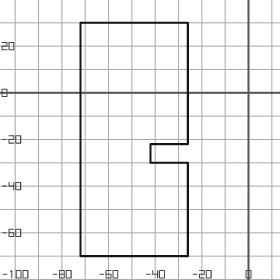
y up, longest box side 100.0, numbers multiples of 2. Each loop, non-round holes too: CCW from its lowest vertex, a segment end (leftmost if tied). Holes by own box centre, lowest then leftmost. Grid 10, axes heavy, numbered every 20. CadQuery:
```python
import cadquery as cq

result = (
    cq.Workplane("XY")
    .moveTo(-72.0, -70.0)
    .lineTo(-26.0, -70.0)
    .lineTo(-26.0, -30.0)
    .lineTo(-42.0, -30.0)
    .lineTo(-42.0, -22.0)
    .lineTo(-26.0, -22.0)
    .lineTo(-26.0, 30.0)
    .lineTo(-72.0, 30.0)
    .close()
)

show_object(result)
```